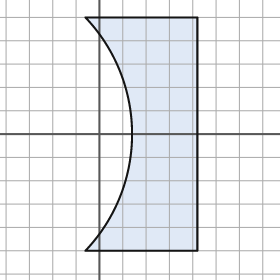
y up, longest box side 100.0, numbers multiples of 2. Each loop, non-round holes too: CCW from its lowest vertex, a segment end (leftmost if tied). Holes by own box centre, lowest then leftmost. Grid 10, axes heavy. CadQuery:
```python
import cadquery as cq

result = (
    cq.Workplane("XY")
    .moveTo(-6.0, -50.0)
    .lineTo(42.0, -50.0)
    .lineTo(42.0, 50.0)
    .lineTo(-6.0, 50.0)
    .threePointArc((14.0, 0.0), (-6.0, -50.0))
    .close()
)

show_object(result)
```